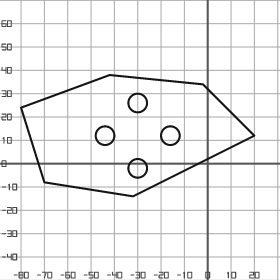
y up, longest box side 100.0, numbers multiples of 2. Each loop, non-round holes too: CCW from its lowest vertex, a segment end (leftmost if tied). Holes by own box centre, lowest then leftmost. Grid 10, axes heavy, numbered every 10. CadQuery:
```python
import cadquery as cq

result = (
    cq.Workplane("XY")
    .moveTo(-32.0, -14.0)
    .lineTo(20.0, 12.0)
    .lineTo(-2.0, 34.0)
    .lineTo(-42.0, 38.0)
    .lineTo(-80.0, 24.0)
    .lineTo(-70.0, -8.0)
    .close()
    .moveTo(-30.0, -2.0)
    .circle(4.0)
    .moveTo(-44.0, 12.0)
    .circle(4.0)
    .moveTo(-16.0, 12.0)
    .circle(4.0)
    .moveTo(-30.0, 26.0)
    .circle(4.0)
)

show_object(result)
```